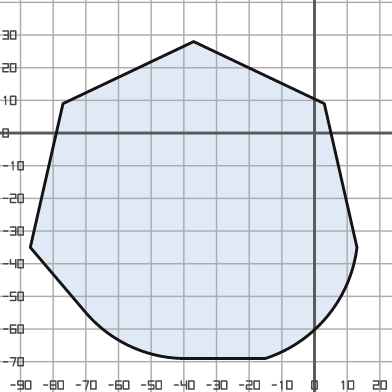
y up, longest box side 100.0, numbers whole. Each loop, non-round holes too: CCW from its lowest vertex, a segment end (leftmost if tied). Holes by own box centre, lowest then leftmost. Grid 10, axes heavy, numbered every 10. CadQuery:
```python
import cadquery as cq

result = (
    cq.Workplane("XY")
    .moveTo(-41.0, -69.0)
    .lineTo(-15.0, -69.0)
    .threePointArc((4.0, -56.0), (13.0, -35.0))
    .lineTo(3.0, 9.0)
    .lineTo(-37.0, 28.0)
    .lineTo(-77.0, 9.0)
    .lineTo(-87.0, -35.0)
    .lineTo(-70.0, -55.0)
    .threePointArc((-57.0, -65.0), (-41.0, -69.0))
    .close()
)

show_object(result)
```